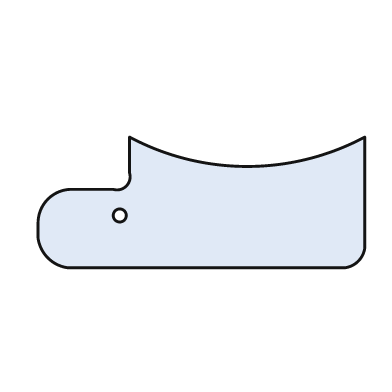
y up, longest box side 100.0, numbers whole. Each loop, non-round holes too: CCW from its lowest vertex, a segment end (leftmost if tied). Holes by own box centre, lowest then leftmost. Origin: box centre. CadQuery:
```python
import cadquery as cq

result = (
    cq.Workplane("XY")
    .moveTo(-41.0, -20.0)
    .lineTo(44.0, -20.0)
    .threePointArc((48.0, -18.0), (50.0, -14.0))
    .lineTo(50.0, 20.0)
    .threePointArc((14.0, 11.0), (-22.0, 20.0))
    .lineTo(-22.0, 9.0)
    .threePointArc((-23.0, 5.0), (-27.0, 4.0))
    .lineTo(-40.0, 4.0)
    .threePointArc((-47.0, 1.0), (-50.0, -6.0))
    .lineTo(-50.0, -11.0)
    .threePointArc((-47.0, -17.0), (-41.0, -20.0))
    .close()
    .moveTo(-25.0, -4.0)
    .circle(2.0)
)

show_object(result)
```